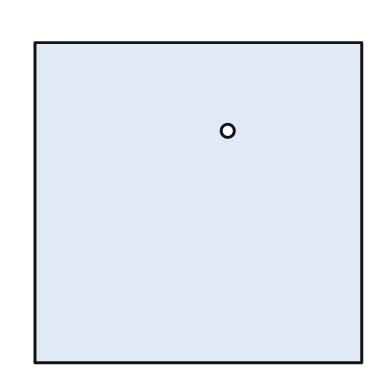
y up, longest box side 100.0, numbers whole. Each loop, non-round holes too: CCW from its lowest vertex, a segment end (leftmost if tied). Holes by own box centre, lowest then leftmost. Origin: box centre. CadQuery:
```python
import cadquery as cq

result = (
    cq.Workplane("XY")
    .moveTo(-50.0, -49.0)
    .lineTo(50.0, -49.0)
    .lineTo(50.0, 49.0)
    .lineTo(-50.0, 49.0)
    .close()
    .moveTo(9.0, 22.0)
    .circle(2.0)
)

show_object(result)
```